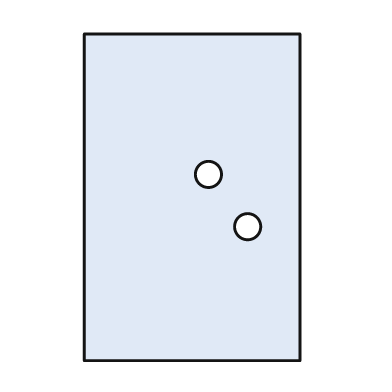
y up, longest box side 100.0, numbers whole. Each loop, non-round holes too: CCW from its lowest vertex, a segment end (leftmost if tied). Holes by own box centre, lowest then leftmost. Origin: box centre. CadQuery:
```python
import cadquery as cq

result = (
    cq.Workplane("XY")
    .moveTo(-33.0, -50.0)
    .lineTo(33.0, -50.0)
    .lineTo(33.0, 50.0)
    .lineTo(-33.0, 50.0)
    .close()
    .moveTo(17.0, -9.0)
    .circle(4.0)
    .moveTo(5.0, 7.0)
    .circle(4.0)
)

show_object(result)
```